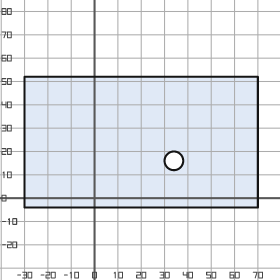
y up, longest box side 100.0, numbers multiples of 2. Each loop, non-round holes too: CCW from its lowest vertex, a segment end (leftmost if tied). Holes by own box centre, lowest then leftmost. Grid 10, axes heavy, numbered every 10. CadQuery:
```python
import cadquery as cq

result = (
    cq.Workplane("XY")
    .moveTo(-30.0, -4.0)
    .lineTo(70.0, -4.0)
    .lineTo(70.0, 52.0)
    .lineTo(-30.0, 52.0)
    .close()
    .moveTo(34.0, 16.0)
    .circle(4.0)
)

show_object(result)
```